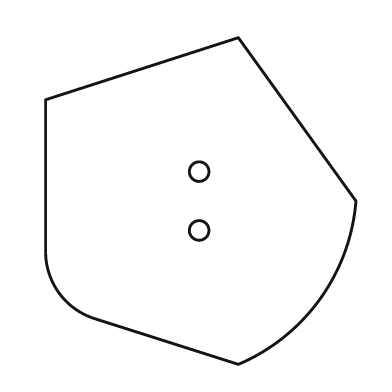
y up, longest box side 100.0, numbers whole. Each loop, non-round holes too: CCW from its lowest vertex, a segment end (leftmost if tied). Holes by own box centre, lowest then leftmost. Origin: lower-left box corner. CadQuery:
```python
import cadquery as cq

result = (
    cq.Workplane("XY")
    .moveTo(59.0, 0.0)
    .threePointArc((84.0, 20.0), (95.0, 50.0))
    .lineTo(59.0, 100.0)
    .lineTo(0.0, 81.0)
    .lineTo(0.0, 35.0)
    .threePointArc((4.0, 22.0), (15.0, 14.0))
    .close()
    .moveTo(47.0, 41.0)
    .circle(3.0)
    .moveTo(47.0, 59.0)
    .circle(3.0)
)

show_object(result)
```